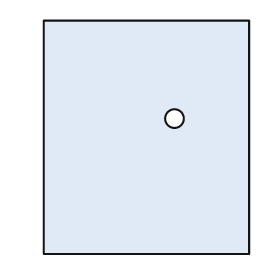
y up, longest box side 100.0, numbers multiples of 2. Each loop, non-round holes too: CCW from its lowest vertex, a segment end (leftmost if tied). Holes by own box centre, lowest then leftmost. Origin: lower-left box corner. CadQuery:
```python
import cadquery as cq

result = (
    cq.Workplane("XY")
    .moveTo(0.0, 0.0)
    .lineTo(88.0, 0.0)
    .lineTo(88.0, 100.0)
    .lineTo(0.0, 100.0)
    .close()
    .moveTo(56.0, 58.0)
    .circle(4.0)
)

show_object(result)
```